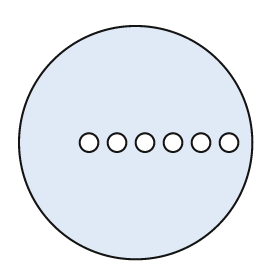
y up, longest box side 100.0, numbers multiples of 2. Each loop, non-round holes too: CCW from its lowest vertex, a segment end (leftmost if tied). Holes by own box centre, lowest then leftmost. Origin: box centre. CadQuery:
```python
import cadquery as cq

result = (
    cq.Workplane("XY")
    .moveTo(0.0, 0.0)
    .circle(50.0)
    .moveTo(-20.0, 0.0)
    .circle(4.0)
    .moveTo(-8.0, 0.0)
    .circle(4.0)
    .moveTo(4.0, 0.0)
    .circle(4.0)
    .moveTo(16.0, 0.0)
    .circle(4.0)
    .moveTo(28.0, 0.0)
    .circle(4.0)
    .moveTo(40.0, 0.0)
    .circle(4.0)
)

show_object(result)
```